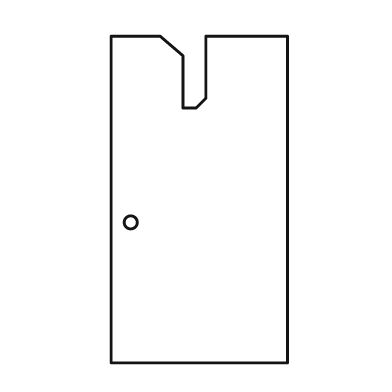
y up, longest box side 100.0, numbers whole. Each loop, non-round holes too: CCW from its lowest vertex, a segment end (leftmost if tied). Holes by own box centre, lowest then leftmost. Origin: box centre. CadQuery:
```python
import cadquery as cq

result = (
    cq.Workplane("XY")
    .moveTo(-27.0, -50.0)
    .lineTo(27.0, -50.0)
    .lineTo(27.0, 50.0)
    .lineTo(2.0, 50.0)
    .lineTo(2.0, 31.0)
    .lineTo(-1.0, 28.0)
    .lineTo(-5.0, 28.0)
    .lineTo(-5.0, 44.0)
    .lineTo(-12.0, 50.0)
    .lineTo(-27.0, 50.0)
    .close()
    .moveTo(-21.0, -7.0)
    .circle(2.0)
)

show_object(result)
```